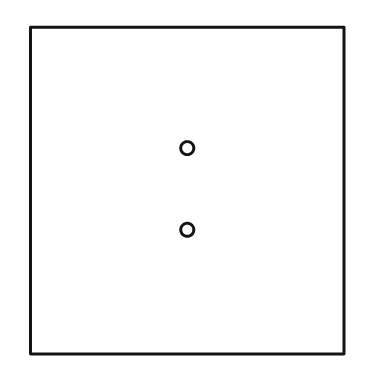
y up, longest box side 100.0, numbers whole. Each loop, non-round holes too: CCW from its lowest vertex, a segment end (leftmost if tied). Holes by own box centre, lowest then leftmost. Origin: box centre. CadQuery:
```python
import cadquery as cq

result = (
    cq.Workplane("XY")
    .moveTo(-48.0, -50.0)
    .lineTo(48.0, -50.0)
    .lineTo(48.0, 50.0)
    .lineTo(-48.0, 50.0)
    .close()
    .moveTo(0.0, -12.0)
    .circle(2.0)
    .moveTo(0.0, 13.0)
    .circle(2.0)
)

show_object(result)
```